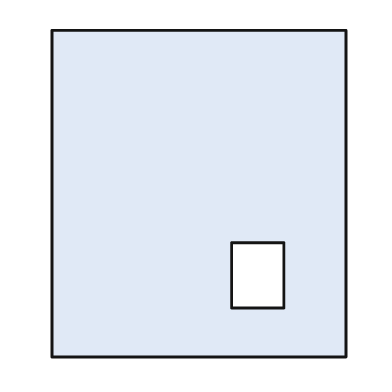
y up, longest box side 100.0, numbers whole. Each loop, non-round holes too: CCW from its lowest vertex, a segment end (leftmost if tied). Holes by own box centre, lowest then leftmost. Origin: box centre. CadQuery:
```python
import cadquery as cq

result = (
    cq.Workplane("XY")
    .moveTo(-45.0, -50.0)
    .lineTo(45.0, -50.0)
    .lineTo(45.0, 50.0)
    .lineTo(-45.0, 50.0)
    .close()
    .moveTo(10.0, -35.0)
    .lineTo(26.0, -35.0)
    .lineTo(26.0, -15.0)
    .lineTo(10.0, -15.0)
    .close()
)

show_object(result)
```